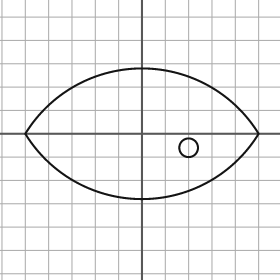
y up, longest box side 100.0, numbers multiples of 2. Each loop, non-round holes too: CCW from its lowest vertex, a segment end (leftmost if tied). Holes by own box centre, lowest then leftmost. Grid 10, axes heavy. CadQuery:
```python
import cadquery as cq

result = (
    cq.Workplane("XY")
    .moveTo(-50.0, 0.0)
    .threePointArc((0.0, -28.0), (50.0, 0.0))
    .threePointArc((0.0, 28.0), (-50.0, 0.0))
    .close()
    .moveTo(20.0, -6.0)
    .circle(4.0)
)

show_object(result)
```